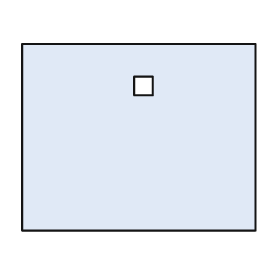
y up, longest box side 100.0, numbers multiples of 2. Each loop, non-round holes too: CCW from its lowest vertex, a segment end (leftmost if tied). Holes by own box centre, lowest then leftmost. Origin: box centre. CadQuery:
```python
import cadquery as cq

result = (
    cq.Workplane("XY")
    .moveTo(-50.0, -40.0)
    .lineTo(50.0, -40.0)
    .lineTo(50.0, 40.0)
    .lineTo(-50.0, 40.0)
    .close()
    .moveTo(-2.0, 18.0)
    .lineTo(6.0, 18.0)
    .lineTo(6.0, 26.0)
    .lineTo(-2.0, 26.0)
    .close()
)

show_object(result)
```